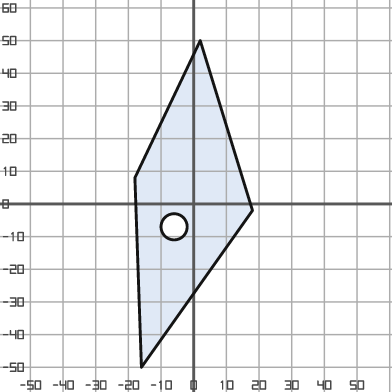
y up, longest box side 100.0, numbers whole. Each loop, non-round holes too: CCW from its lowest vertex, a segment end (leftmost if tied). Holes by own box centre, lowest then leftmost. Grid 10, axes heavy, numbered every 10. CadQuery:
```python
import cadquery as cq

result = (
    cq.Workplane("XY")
    .moveTo(-16.0, -50.0)
    .lineTo(18.0, -2.0)
    .lineTo(2.0, 50.0)
    .lineTo(-18.0, 8.0)
    .close()
    .moveTo(-6.0, -7.0)
    .circle(4.0)
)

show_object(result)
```